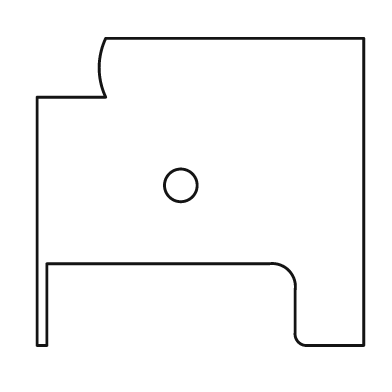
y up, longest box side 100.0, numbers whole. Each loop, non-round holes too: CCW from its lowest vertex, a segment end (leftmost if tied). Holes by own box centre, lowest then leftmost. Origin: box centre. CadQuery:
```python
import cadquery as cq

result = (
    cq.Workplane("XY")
    .moveTo(-50.0, -47.0)
    .lineTo(-47.0, -47.0)
    .lineTo(-47.0, -22.0)
    .lineTo(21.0, -22.0)
    .threePointArc((27.0, -24.0), (29.0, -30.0))
    .lineTo(29.0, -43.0)
    .threePointArc((30.0, -46.0), (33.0, -47.0))
    .lineTo(50.0, -47.0)
    .lineTo(50.0, 47.0)
    .lineTo(-29.0, 47.0)
    .threePointArc((-31.0, 38.0), (-29.0, 29.0))
    .lineTo(-50.0, 29.0)
    .close()
    .moveTo(-6.0, 2.0)
    .circle(5.0)
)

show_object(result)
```